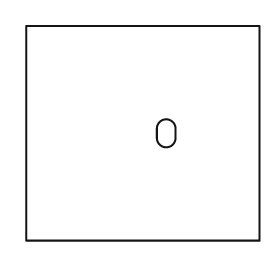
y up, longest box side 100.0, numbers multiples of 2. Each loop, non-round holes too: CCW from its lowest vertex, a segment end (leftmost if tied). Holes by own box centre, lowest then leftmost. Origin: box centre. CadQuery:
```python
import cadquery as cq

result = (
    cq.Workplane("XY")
    .moveTo(-50.0, -46.0)
    .lineTo(50.0, -46.0)
    .lineTo(50.0, 46.0)
    .lineTo(-50.0, 46.0)
    .close()
    .moveTo(6.0, -2.0)
    .threePointArc((10.0, -6.0), (14.0, -2.0))
    .lineTo(14.0, 2.0)
    .threePointArc((10.0, 6.0), (6.0, 2.0))
    .close()
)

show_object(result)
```